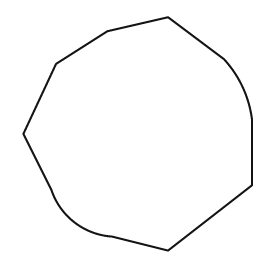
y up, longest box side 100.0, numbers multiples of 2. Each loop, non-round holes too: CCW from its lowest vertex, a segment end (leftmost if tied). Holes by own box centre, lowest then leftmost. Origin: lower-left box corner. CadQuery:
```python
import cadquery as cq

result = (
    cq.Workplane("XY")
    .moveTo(62.0, 0.0)
    .lineTo(98.0, 28.0)
    .lineTo(98.0, 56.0)
    .threePointArc((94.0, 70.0), (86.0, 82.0))
    .lineTo(62.0, 100.0)
    .lineTo(36.0, 94.0)
    .lineTo(14.0, 80.0)
    .lineTo(0.0, 50.0)
    .lineTo(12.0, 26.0)
    .threePointArc((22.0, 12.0), (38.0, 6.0))
    .close()
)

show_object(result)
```